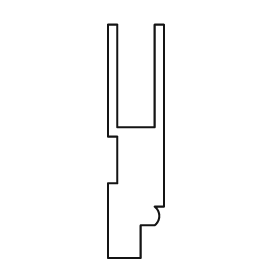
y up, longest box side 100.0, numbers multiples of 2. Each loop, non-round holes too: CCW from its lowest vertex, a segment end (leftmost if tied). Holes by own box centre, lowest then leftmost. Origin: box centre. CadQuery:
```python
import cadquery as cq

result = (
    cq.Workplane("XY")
    .moveTo(-12.0, -50.0)
    .lineTo(2.0, -50.0)
    .lineTo(2.0, -36.0)
    .lineTo(8.0, -36.0)
    .threePointArc((10.0, -32.0), (8.0, -28.0))
    .lineTo(12.0, -28.0)
    .lineTo(12.0, 50.0)
    .lineTo(8.0, 50.0)
    .lineTo(8.0, 6.0)
    .lineTo(-8.0, 6.0)
    .lineTo(-8.0, 50.0)
    .lineTo(-12.0, 50.0)
    .lineTo(-12.0, 2.0)
    .lineTo(-8.0, 2.0)
    .lineTo(-8.0, -18.0)
    .lineTo(-12.0, -18.0)
    .close()
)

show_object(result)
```